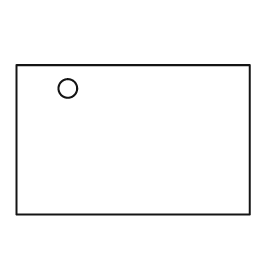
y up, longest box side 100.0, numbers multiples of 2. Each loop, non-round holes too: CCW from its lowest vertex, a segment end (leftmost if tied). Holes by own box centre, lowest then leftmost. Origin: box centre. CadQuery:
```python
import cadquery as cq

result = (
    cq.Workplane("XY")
    .moveTo(-50.0, -32.0)
    .lineTo(50.0, -32.0)
    .lineTo(50.0, 32.0)
    .lineTo(-50.0, 32.0)
    .close()
    .moveTo(-28.0, 22.0)
    .circle(4.0)
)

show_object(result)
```